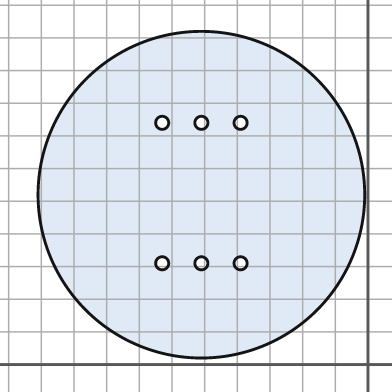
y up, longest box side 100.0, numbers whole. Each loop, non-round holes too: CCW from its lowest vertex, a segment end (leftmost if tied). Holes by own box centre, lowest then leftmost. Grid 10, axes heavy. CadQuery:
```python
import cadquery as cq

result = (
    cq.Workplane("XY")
    .moveTo(-51.0, 52.0)
    .circle(50.0)
    .moveTo(-63.0, 31.0)
    .circle(2.0)
    .moveTo(-51.0, 31.0)
    .circle(2.0)
    .moveTo(-39.0, 31.0)
    .circle(2.0)
    .moveTo(-63.0, 74.0)
    .circle(2.0)
    .moveTo(-51.0, 74.0)
    .circle(2.0)
    .moveTo(-39.0, 74.0)
    .circle(2.0)
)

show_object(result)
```